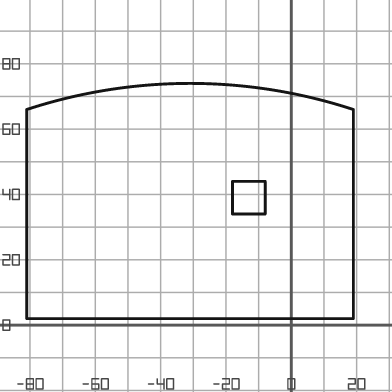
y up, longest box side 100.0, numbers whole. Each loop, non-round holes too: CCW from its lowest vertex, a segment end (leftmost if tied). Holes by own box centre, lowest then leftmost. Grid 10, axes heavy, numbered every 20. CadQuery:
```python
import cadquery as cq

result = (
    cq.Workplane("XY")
    .moveTo(-81.0, 2.0)
    .lineTo(19.0, 2.0)
    .lineTo(19.0, 66.0)
    .threePointArc((-31.0, 74.0), (-81.0, 66.0))
    .close()
    .moveTo(-18.0, 34.0)
    .lineTo(-8.0, 34.0)
    .lineTo(-8.0, 44.0)
    .lineTo(-18.0, 44.0)
    .close()
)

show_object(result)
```